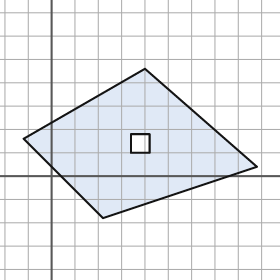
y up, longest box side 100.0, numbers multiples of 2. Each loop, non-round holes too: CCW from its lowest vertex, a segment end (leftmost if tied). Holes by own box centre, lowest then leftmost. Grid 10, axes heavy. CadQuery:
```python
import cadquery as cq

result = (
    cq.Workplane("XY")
    .moveTo(22.0, -18.0)
    .lineTo(88.0, 4.0)
    .lineTo(40.0, 46.0)
    .lineTo(-12.0, 16.0)
    .close()
    .moveTo(34.0, 10.0)
    .lineTo(42.0, 10.0)
    .lineTo(42.0, 18.0)
    .lineTo(34.0, 18.0)
    .close()
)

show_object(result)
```